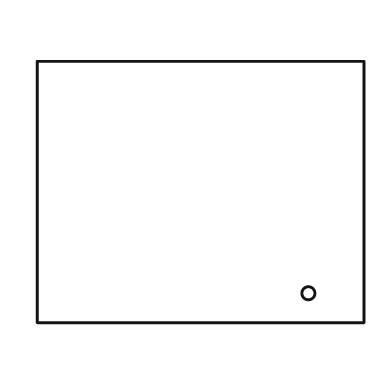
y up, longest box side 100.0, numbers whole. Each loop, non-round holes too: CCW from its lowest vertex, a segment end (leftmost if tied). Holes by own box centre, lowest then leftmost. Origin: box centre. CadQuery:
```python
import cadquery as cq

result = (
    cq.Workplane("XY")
    .moveTo(-50.0, -40.0)
    .lineTo(50.0, -40.0)
    .lineTo(50.0, 40.0)
    .lineTo(-50.0, 40.0)
    .close()
    .moveTo(33.0, -31.0)
    .circle(2.0)
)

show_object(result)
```